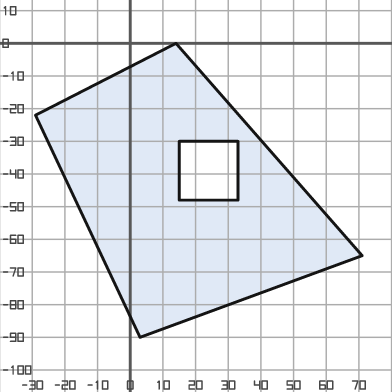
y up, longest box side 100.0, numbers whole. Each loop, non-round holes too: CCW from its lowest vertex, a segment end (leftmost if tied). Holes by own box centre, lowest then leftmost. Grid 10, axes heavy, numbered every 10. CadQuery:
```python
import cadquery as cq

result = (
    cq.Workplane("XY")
    .moveTo(3.0, -90.0)
    .lineTo(71.0, -65.0)
    .lineTo(14.0, 0.0)
    .lineTo(-29.0, -22.0)
    .close()
    .moveTo(15.0, -48.0)
    .lineTo(33.0, -48.0)
    .lineTo(33.0, -30.0)
    .lineTo(15.0, -30.0)
    .close()
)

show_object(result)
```